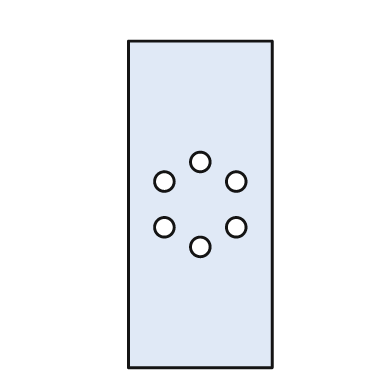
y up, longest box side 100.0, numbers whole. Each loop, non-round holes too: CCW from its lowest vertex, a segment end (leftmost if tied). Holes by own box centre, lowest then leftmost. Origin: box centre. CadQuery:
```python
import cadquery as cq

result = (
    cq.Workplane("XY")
    .moveTo(-22.0, -50.0)
    .lineTo(22.0, -50.0)
    .lineTo(22.0, 50.0)
    .lineTo(-22.0, 50.0)
    .close()
    .moveTo(0.0, -13.0)
    .circle(3.0)
    .moveTo(-11.0, -7.0)
    .circle(3.0)
    .moveTo(11.0, -7.0)
    .circle(3.0)
    .moveTo(-11.0, 7.0)
    .circle(3.0)
    .moveTo(11.0, 7.0)
    .circle(3.0)
    .moveTo(0.0, 13.0)
    .circle(3.0)
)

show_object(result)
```